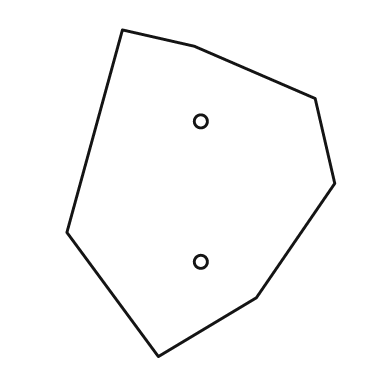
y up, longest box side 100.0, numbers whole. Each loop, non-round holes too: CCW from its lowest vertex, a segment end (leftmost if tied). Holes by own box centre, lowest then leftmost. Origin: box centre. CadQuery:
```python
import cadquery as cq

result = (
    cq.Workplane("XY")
    .moveTo(-13.0, -50.0)
    .lineTo(17.0, -32.0)
    .lineTo(41.0, 3.0)
    .lineTo(35.0, 29.0)
    .lineTo(-2.0, 45.0)
    .lineTo(-24.0, 50.0)
    .lineTo(-41.0, -12.0)
    .close()
    .moveTo(0.0, -21.0)
    .circle(2.0)
    .moveTo(0.0, 22.0)
    .circle(2.0)
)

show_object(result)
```